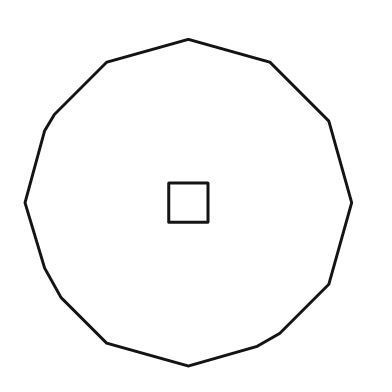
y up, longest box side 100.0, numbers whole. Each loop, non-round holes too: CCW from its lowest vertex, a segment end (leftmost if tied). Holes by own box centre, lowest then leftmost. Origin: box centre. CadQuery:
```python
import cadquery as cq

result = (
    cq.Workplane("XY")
    .moveTo(0.0, -50.0)
    .lineTo(21.0, -44.0)
    .lineTo(28.0, -40.0)
    .lineTo(43.0, -25.0)
    .lineTo(50.0, 0.0)
    .lineTo(43.0, 25.0)
    .lineTo(25.0, 43.0)
    .lineTo(0.0, 50.0)
    .lineTo(-25.0, 43.0)
    .lineTo(-41.0, 27.0)
    .lineTo(-44.0, 22.0)
    .lineTo(-50.0, 0.0)
    .lineTo(-44.0, -20.0)
    .lineTo(-39.0, -29.0)
    .lineTo(-25.0, -43.0)
    .close()
    .moveTo(-6.0, -6.0)
    .lineTo(6.0, -6.0)
    .lineTo(6.0, 6.0)
    .lineTo(-6.0, 6.0)
    .close()
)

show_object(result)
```